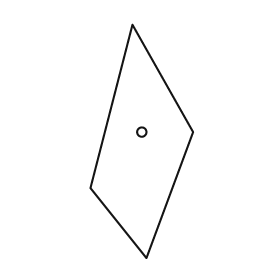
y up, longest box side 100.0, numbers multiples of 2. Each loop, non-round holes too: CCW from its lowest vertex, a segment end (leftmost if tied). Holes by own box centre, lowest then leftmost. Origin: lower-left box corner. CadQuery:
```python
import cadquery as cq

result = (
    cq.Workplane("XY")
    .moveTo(24.0, 0.0)
    .lineTo(44.0, 54.0)
    .lineTo(18.0, 100.0)
    .lineTo(0.0, 30.0)
    .close()
    .moveTo(22.0, 54.0)
    .circle(2.0)
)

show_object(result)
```